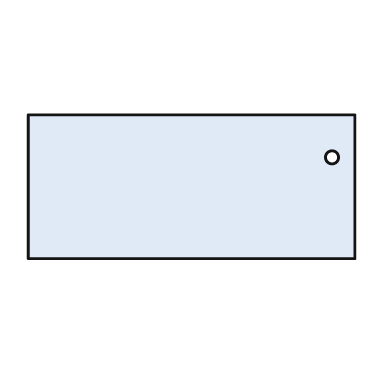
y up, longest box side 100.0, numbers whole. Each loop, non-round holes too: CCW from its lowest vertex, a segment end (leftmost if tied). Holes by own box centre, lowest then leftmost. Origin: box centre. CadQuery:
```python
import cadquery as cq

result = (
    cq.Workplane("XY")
    .moveTo(-50.0, -22.0)
    .lineTo(50.0, -22.0)
    .lineTo(50.0, 22.0)
    .lineTo(-50.0, 22.0)
    .close()
    .moveTo(43.0, 9.0)
    .circle(2.0)
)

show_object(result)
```